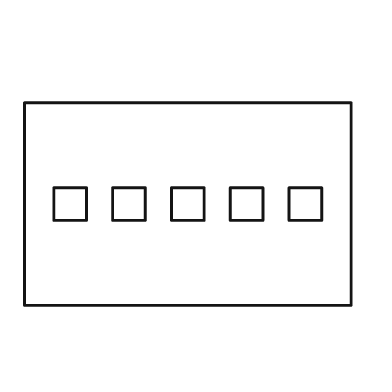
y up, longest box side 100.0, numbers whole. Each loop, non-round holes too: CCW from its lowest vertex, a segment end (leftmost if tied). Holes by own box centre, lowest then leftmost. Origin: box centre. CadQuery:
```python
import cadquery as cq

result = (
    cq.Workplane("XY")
    .moveTo(-50.0, -31.0)
    .lineTo(50.0, -31.0)
    .lineTo(50.0, 31.0)
    .lineTo(-50.0, 31.0)
    .close()
    .moveTo(-41.0, -5.0)
    .lineTo(-31.0, -5.0)
    .lineTo(-31.0, 5.0)
    .lineTo(-41.0, 5.0)
    .close()
    .moveTo(-23.0, -5.0)
    .lineTo(-13.0, -5.0)
    .lineTo(-13.0, 5.0)
    .lineTo(-23.0, 5.0)
    .close()
    .moveTo(-5.0, -5.0)
    .lineTo(5.0, -5.0)
    .lineTo(5.0, 5.0)
    .lineTo(-5.0, 5.0)
    .close()
    .moveTo(13.0, -5.0)
    .lineTo(23.0, -5.0)
    .lineTo(23.0, 5.0)
    .lineTo(13.0, 5.0)
    .close()
    .moveTo(31.0, -5.0)
    .lineTo(41.0, -5.0)
    .lineTo(41.0, 5.0)
    .lineTo(31.0, 5.0)
    .close()
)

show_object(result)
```